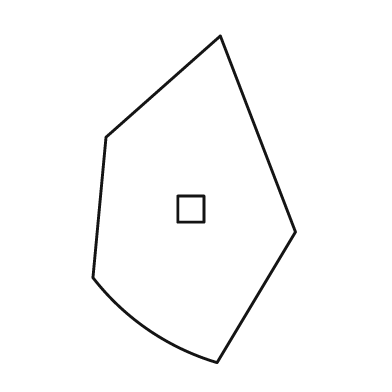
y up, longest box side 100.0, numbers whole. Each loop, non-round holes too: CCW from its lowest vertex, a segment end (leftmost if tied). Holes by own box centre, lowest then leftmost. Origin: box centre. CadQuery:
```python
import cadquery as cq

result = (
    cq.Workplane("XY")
    .moveTo(7.0, -50.0)
    .lineTo(31.0, -10.0)
    .lineTo(8.0, 50.0)
    .lineTo(-27.0, 19.0)
    .lineTo(-31.0, -24.0)
    .threePointArc((-14.0, -40.0), (7.0, -50.0))
    .close()
    .moveTo(-5.0, -7.0)
    .lineTo(3.0, -7.0)
    .lineTo(3.0, 1.0)
    .lineTo(-5.0, 1.0)
    .close()
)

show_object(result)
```